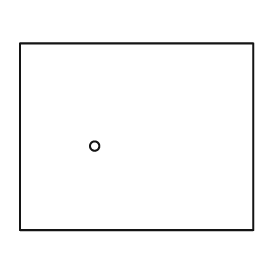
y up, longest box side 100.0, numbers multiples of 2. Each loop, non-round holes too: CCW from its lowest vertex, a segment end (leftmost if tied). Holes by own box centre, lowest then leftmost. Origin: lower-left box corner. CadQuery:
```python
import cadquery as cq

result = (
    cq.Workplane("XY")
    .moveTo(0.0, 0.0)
    .lineTo(100.0, 0.0)
    .lineTo(100.0, 80.0)
    .lineTo(0.0, 80.0)
    .close()
    .moveTo(32.0, 36.0)
    .circle(2.0)
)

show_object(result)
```